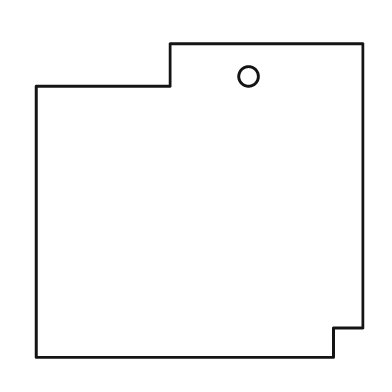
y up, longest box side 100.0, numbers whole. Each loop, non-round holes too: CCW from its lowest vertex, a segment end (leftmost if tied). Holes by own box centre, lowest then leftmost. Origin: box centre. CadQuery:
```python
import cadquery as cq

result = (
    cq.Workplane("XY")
    .moveTo(-50.0, -48.0)
    .lineTo(41.0, -48.0)
    .lineTo(41.0, -39.0)
    .lineTo(50.0, -39.0)
    .lineTo(50.0, 48.0)
    .lineTo(-9.0, 48.0)
    .lineTo(-9.0, 35.0)
    .lineTo(-50.0, 35.0)
    .close()
    .moveTo(15.0, 38.0)
    .circle(3.0)
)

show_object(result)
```